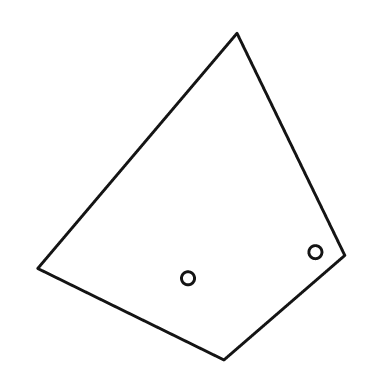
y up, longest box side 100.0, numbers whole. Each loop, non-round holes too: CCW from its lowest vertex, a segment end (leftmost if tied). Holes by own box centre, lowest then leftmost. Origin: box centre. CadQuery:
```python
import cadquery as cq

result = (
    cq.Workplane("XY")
    .moveTo(10.0, -50.0)
    .lineTo(47.0, -18.0)
    .lineTo(14.0, 50.0)
    .lineTo(-47.0, -22.0)
    .close()
    .moveTo(-1.0, -25.0)
    .circle(2.0)
    .moveTo(38.0, -17.0)
    .circle(2.0)
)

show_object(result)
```